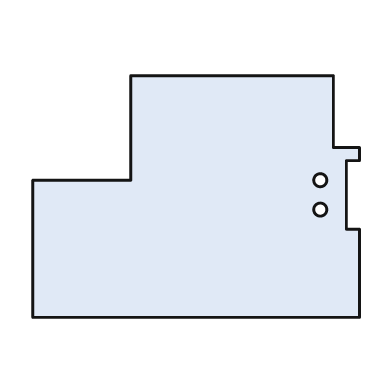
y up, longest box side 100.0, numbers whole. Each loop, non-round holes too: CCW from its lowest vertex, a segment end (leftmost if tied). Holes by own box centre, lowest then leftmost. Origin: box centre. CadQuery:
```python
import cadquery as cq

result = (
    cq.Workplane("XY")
    .moveTo(-50.0, -37.0)
    .lineTo(50.0, -37.0)
    .lineTo(50.0, -10.0)
    .lineTo(46.0, -10.0)
    .lineTo(46.0, 11.0)
    .lineTo(50.0, 11.0)
    .lineTo(50.0, 15.0)
    .lineTo(42.0, 15.0)
    .lineTo(42.0, 37.0)
    .lineTo(-20.0, 37.0)
    .lineTo(-20.0, 5.0)
    .lineTo(-50.0, 5.0)
    .close()
    .moveTo(38.0, -4.0)
    .circle(2.0)
    .moveTo(38.0, 5.0)
    .circle(2.0)
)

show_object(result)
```